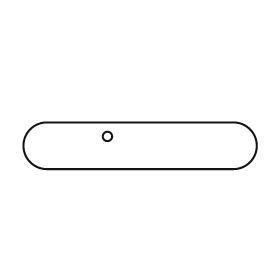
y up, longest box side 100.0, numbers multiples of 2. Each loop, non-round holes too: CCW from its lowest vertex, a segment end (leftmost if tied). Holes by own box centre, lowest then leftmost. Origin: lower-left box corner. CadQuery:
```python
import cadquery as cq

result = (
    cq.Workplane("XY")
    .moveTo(10.0, 0.0)
    .lineTo(90.0, 0.0)
    .threePointArc((100.0, 10.0), (90.0, 20.0))
    .lineTo(10.0, 20.0)
    .threePointArc((0.0, 10.0), (10.0, 0.0))
    .close()
    .moveTo(36.0, 14.0)
    .circle(2.0)
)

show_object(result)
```